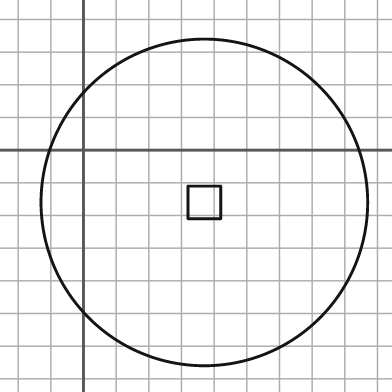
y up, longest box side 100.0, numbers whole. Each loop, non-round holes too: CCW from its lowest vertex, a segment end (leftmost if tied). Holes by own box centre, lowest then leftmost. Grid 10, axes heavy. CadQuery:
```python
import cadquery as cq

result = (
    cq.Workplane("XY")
    .moveTo(37.0, -16.0)
    .circle(50.0)
    .moveTo(32.0, -21.0)
    .lineTo(42.0, -21.0)
    .lineTo(42.0, -11.0)
    .lineTo(32.0, -11.0)
    .close()
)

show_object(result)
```